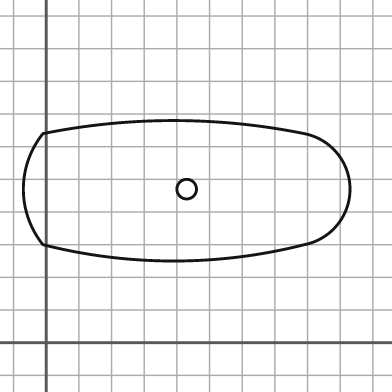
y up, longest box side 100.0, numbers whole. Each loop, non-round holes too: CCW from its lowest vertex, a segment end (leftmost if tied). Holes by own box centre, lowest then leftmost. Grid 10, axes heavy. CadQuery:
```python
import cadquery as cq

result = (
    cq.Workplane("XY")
    .moveTo(-1.0, 30.0)
    .threePointArc((39.0, 25.0), (79.0, 30.0))
    .threePointArc((93.0, 47.0), (79.0, 64.0))
    .threePointArc((39.0, 68.0), (-1.0, 64.0))
    .threePointArc((-7.0, 47.0), (-1.0, 30.0))
    .close()
    .moveTo(43.0, 47.0)
    .circle(3.0)
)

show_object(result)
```